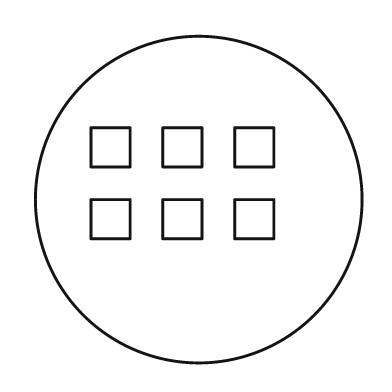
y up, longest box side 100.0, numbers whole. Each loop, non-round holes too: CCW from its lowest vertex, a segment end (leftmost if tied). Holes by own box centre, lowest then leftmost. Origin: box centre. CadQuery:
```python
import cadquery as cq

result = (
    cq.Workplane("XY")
    .moveTo(0.0, 0.0)
    .circle(50.0)
    .moveTo(-33.0, -12.0)
    .lineTo(-21.0, -12.0)
    .lineTo(-21.0, 0.0)
    .lineTo(-33.0, 0.0)
    .close()
    .moveTo(-11.0, -12.0)
    .lineTo(1.0, -12.0)
    .lineTo(1.0, 0.0)
    .lineTo(-11.0, 0.0)
    .close()
    .moveTo(11.0, -12.0)
    .lineTo(23.0, -12.0)
    .lineTo(23.0, 0.0)
    .lineTo(11.0, 0.0)
    .close()
    .moveTo(-33.0, 10.0)
    .lineTo(-21.0, 10.0)
    .lineTo(-21.0, 22.0)
    .lineTo(-33.0, 22.0)
    .close()
    .moveTo(-11.0, 10.0)
    .lineTo(1.0, 10.0)
    .lineTo(1.0, 22.0)
    .lineTo(-11.0, 22.0)
    .close()
    .moveTo(11.0, 10.0)
    .lineTo(23.0, 10.0)
    .lineTo(23.0, 22.0)
    .lineTo(11.0, 22.0)
    .close()
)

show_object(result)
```